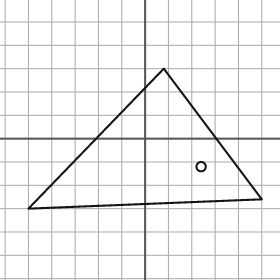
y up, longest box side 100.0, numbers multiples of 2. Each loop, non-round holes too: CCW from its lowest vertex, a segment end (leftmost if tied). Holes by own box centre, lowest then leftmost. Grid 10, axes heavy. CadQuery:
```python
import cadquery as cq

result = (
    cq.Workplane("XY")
    .moveTo(-50.0, -30.0)
    .lineTo(50.0, -26.0)
    .lineTo(8.0, 30.0)
    .close()
    .moveTo(24.0, -12.0)
    .circle(2.0)
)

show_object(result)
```